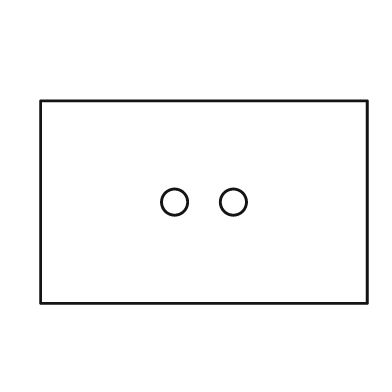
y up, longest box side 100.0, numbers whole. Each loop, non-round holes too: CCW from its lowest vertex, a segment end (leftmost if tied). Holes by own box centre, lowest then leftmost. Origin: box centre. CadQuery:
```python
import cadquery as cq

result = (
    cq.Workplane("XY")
    .moveTo(-50.0, -31.0)
    .lineTo(50.0, -31.0)
    .lineTo(50.0, 31.0)
    .lineTo(-50.0, 31.0)
    .close()
    .moveTo(-9.0, 0.0)
    .circle(4.0)
    .moveTo(9.0, 0.0)
    .circle(4.0)
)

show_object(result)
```